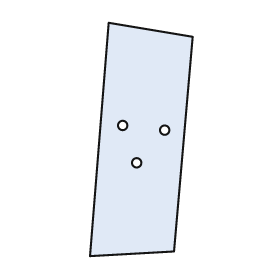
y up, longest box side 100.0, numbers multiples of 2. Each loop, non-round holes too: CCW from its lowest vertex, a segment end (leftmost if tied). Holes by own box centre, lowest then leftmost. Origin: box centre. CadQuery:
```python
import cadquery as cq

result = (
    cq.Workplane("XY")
    .moveTo(-22.0, -50.0)
    .lineTo(14.0, -48.0)
    .lineTo(22.0, 44.0)
    .lineTo(-14.0, 50.0)
    .close()
    .moveTo(-2.0, -10.0)
    .circle(2.0)
    .moveTo(10.0, 4.0)
    .circle(2.0)
    .moveTo(-8.0, 6.0)
    .circle(2.0)
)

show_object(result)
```